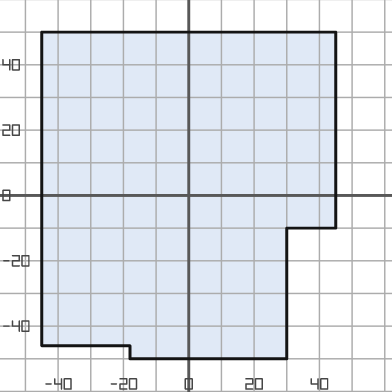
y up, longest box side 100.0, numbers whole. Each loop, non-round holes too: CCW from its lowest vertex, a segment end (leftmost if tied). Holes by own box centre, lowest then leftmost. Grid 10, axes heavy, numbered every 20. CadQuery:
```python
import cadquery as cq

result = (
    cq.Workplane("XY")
    .moveTo(-18.0, -50.0)
    .lineTo(30.0, -50.0)
    .lineTo(30.0, -10.0)
    .lineTo(45.0, -10.0)
    .lineTo(45.0, 50.0)
    .lineTo(-45.0, 50.0)
    .lineTo(-45.0, -46.0)
    .lineTo(-18.0, -46.0)
    .close()
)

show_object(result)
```